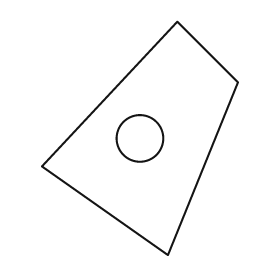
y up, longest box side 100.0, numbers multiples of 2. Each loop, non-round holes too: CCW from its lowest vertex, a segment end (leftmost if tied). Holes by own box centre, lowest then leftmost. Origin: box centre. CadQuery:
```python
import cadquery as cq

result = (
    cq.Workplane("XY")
    .moveTo(12.0, -50.0)
    .lineTo(42.0, 24.0)
    .lineTo(16.0, 50.0)
    .lineTo(-42.0, -12.0)
    .close()
    .moveTo(0.0, 0.0)
    .circle(10.0)
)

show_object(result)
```